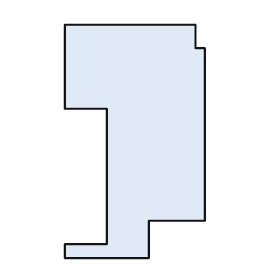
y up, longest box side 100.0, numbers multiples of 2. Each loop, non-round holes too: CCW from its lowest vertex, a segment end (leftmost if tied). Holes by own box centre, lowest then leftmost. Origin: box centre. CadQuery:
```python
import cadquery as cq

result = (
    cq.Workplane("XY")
    .moveTo(-30.0, -50.0)
    .lineTo(6.0, -50.0)
    .lineTo(6.0, -34.0)
    .lineTo(30.0, -34.0)
    .lineTo(30.0, 40.0)
    .lineTo(26.0, 40.0)
    .lineTo(26.0, 50.0)
    .lineTo(-30.0, 50.0)
    .lineTo(-30.0, 14.0)
    .lineTo(-12.0, 14.0)
    .lineTo(-12.0, -44.0)
    .lineTo(-30.0, -44.0)
    .close()
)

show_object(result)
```